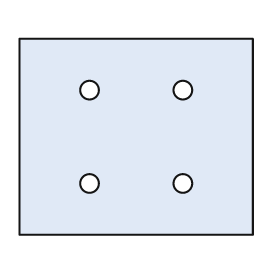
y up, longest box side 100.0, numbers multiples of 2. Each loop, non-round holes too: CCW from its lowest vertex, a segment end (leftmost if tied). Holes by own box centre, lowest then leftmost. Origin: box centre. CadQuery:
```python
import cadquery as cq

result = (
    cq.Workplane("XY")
    .moveTo(-50.0, -42.0)
    .lineTo(50.0, -42.0)
    .lineTo(50.0, 42.0)
    .lineTo(-50.0, 42.0)
    .close()
    .moveTo(-20.0, -20.0)
    .circle(4.0)
    .moveTo(20.0, -20.0)
    .circle(4.0)
    .moveTo(-20.0, 20.0)
    .circle(4.0)
    .moveTo(20.0, 20.0)
    .circle(4.0)
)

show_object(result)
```